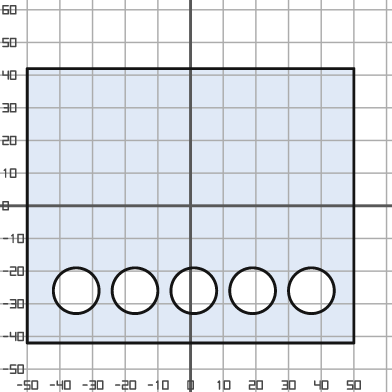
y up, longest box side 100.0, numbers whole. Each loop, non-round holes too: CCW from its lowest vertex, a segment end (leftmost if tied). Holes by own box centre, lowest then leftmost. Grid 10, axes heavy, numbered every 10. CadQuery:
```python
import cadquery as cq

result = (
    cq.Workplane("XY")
    .moveTo(-50.0, -42.0)
    .lineTo(50.0, -42.0)
    .lineTo(50.0, 42.0)
    .lineTo(-50.0, 42.0)
    .close()
    .moveTo(-35.0, -26.0)
    .circle(7.0)
    .moveTo(-17.0, -26.0)
    .circle(7.0)
    .moveTo(1.0, -26.0)
    .circle(7.0)
    .moveTo(19.0, -26.0)
    .circle(7.0)
    .moveTo(37.0, -26.0)
    .circle(7.0)
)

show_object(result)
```